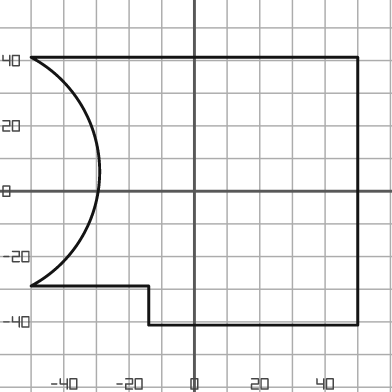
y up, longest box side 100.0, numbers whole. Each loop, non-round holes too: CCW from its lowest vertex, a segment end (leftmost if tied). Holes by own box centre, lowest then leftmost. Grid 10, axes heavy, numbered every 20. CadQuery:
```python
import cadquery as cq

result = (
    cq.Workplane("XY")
    .moveTo(-14.0, -41.0)
    .lineTo(50.0, -41.0)
    .lineTo(50.0, 41.0)
    .lineTo(-50.0, 41.0)
    .threePointArc((-29.0, 6.0), (-50.0, -29.0))
    .lineTo(-14.0, -29.0)
    .close()
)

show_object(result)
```